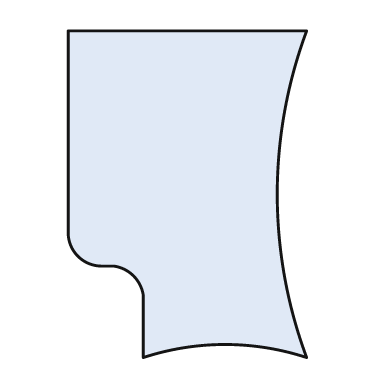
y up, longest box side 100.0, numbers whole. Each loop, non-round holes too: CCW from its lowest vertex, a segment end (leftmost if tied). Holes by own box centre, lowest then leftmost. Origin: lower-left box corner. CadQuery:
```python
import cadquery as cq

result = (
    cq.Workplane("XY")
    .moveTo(23.0, 0.0)
    .threePointArc((48.0, 4.0), (73.0, 0.0))
    .threePointArc((64.0, 50.0), (73.0, 100.0))
    .lineTo(0.0, 100.0)
    .lineTo(0.0, 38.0)
    .threePointArc((3.0, 31.0), (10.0, 28.0))
    .lineTo(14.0, 28.0)
    .threePointArc((20.0, 25.0), (23.0, 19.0))
    .close()
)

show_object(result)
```